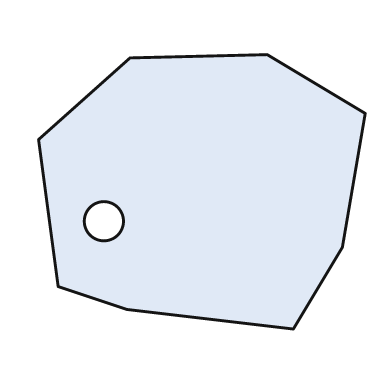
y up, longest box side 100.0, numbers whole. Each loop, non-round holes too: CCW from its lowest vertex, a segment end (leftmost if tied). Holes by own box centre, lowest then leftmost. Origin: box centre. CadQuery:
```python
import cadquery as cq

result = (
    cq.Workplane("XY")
    .moveTo(28.0, -42.0)
    .lineTo(43.0, -17.0)
    .lineTo(50.0, 24.0)
    .lineTo(20.0, 42.0)
    .lineTo(-22.0, 41.0)
    .lineTo(-50.0, 16.0)
    .lineTo(-44.0, -29.0)
    .lineTo(-23.0, -36.0)
    .close()
    .moveTo(-30.0, -9.0)
    .circle(6.0)
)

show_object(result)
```